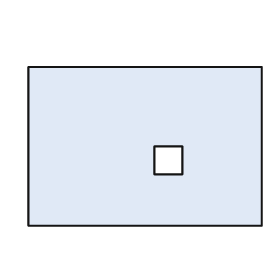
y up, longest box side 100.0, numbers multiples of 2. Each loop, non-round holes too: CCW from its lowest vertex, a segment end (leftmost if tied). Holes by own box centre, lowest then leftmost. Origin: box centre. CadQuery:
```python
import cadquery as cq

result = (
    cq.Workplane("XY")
    .moveTo(-50.0, -34.0)
    .lineTo(50.0, -34.0)
    .lineTo(50.0, 34.0)
    .lineTo(-50.0, 34.0)
    .close()
    .moveTo(4.0, -12.0)
    .lineTo(16.0, -12.0)
    .lineTo(16.0, 0.0)
    .lineTo(4.0, 0.0)
    .close()
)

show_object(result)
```